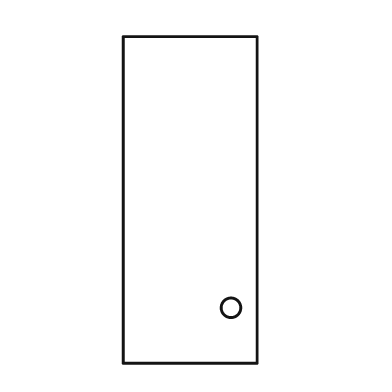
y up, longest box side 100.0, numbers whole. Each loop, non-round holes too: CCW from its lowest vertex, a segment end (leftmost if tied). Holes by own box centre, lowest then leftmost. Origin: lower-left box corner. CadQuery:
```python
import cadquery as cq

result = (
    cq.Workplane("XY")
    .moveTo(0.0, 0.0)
    .lineTo(41.0, 0.0)
    .lineTo(41.0, 100.0)
    .lineTo(0.0, 100.0)
    .close()
    .moveTo(33.0, 17.0)
    .circle(3.0)
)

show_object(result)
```